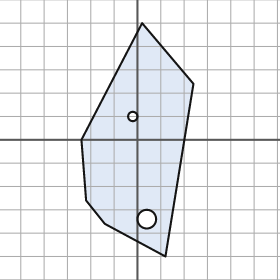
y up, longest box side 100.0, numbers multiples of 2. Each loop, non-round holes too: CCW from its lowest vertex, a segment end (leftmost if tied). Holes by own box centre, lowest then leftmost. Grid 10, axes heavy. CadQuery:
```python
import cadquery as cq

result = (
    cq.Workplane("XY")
    .moveTo(12.0, -50.0)
    .lineTo(24.0, 24.0)
    .lineTo(2.0, 50.0)
    .lineTo(-24.0, 0.0)
    .lineTo(-22.0, -26.0)
    .lineTo(-14.0, -36.0)
    .close()
    .moveTo(4.0, -34.0)
    .circle(4.0)
    .moveTo(-2.0, 10.0)
    .circle(2.0)
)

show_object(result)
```